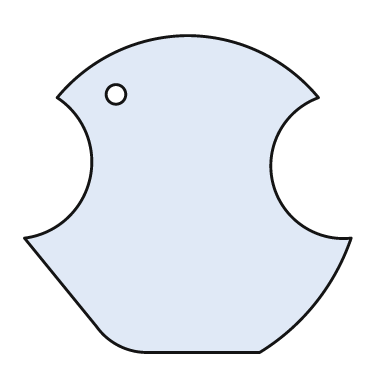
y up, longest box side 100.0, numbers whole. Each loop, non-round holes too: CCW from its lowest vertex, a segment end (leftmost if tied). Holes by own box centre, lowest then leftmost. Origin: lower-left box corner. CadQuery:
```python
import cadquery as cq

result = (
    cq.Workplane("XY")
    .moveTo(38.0, 0.0)
    .lineTo(72.0, 0.0)
    .threePointArc((89.0, 15.0), (100.0, 35.0))
    .threePointArc((76.0, 52.0), (90.0, 78.0))
    .threePointArc((72.0, 92.0), (50.0, 97.0))
    .threePointArc((28.0, 92.0), (10.0, 78.0))
    .threePointArc((20.0, 53.0), (0.0, 35.0))
    .lineTo(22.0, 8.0)
    .threePointArc((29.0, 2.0), (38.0, 0.0))
    .close()
    .moveTo(28.0, 79.0)
    .circle(3.0)
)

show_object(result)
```